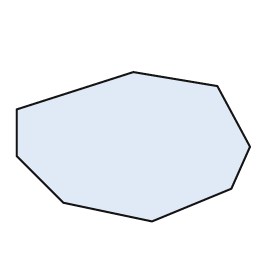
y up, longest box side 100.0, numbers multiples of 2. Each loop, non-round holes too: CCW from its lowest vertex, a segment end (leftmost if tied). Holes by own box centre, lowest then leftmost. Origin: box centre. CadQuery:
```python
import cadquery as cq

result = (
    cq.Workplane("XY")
    .moveTo(8.0, -32.0)
    .lineTo(42.0, -18.0)
    .lineTo(50.0, 0.0)
    .lineTo(36.0, 26.0)
    .lineTo(0.0, 32.0)
    .lineTo(-50.0, 16.0)
    .lineTo(-50.0, -4.0)
    .lineTo(-30.0, -24.0)
    .close()
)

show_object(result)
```